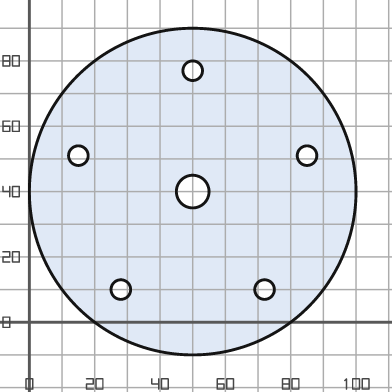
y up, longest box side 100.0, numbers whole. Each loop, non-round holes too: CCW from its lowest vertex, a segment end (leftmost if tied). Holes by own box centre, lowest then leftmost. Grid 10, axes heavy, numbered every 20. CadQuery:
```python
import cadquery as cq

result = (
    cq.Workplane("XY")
    .moveTo(50.0, 40.0)
    .circle(50.0)
    .moveTo(28.0, 10.0)
    .circle(3.0)
    .moveTo(72.0, 10.0)
    .circle(3.0)
    .moveTo(50.0, 40.0)
    .circle(5.0)
    .moveTo(15.0, 51.0)
    .circle(3.0)
    .moveTo(85.0, 51.0)
    .circle(3.0)
    .moveTo(50.0, 77.0)
    .circle(3.0)
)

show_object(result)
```